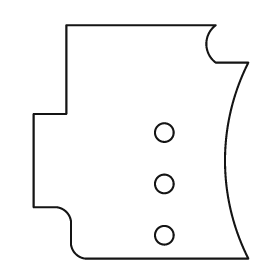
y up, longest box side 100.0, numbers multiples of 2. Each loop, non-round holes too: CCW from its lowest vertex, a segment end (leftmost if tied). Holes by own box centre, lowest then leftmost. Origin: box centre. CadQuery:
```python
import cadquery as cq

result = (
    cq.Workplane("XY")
    .moveTo(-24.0, -50.0)
    .lineTo(46.0, -50.0)
    .threePointArc((36.0, -8.0), (46.0, 34.0))
    .lineTo(32.0, 34.0)
    .threePointArc((28.0, 42.0), (32.0, 50.0))
    .lineTo(-32.0, 50.0)
    .lineTo(-32.0, 12.0)
    .lineTo(-46.0, 12.0)
    .lineTo(-46.0, -28.0)
    .lineTo(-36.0, -28.0)
    .threePointArc((-32.0, -30.0), (-30.0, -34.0))
    .lineTo(-30.0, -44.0)
    .threePointArc((-28.0, -48.0), (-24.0, -50.0))
    .close()
    .moveTo(10.0, -40.0)
    .circle(4.0)
    .moveTo(10.0, -18.0)
    .circle(4.0)
    .moveTo(10.0, 4.0)
    .circle(4.0)
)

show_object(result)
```